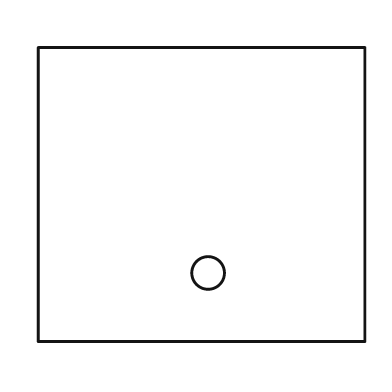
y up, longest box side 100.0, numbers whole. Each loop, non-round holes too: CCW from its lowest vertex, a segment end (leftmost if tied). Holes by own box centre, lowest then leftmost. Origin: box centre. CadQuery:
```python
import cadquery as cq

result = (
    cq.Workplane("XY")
    .moveTo(-50.0, -45.0)
    .lineTo(50.0, -45.0)
    .lineTo(50.0, 45.0)
    .lineTo(-50.0, 45.0)
    .close()
    .moveTo(2.0, -24.0)
    .circle(5.0)
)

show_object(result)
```